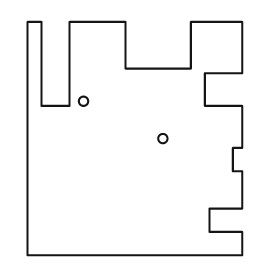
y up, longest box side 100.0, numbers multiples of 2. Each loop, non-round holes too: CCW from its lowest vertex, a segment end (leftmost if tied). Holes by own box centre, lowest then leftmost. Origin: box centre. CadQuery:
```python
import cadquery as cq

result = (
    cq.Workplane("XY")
    .moveTo(-46.0, -50.0)
    .lineTo(46.0, -50.0)
    .lineTo(46.0, -40.0)
    .lineTo(32.0, -40.0)
    .lineTo(32.0, -30.0)
    .lineTo(46.0, -30.0)
    .lineTo(46.0, -14.0)
    .lineTo(42.0, -14.0)
    .lineTo(42.0, -4.0)
    .lineTo(46.0, -4.0)
    .lineTo(46.0, 14.0)
    .lineTo(30.0, 14.0)
    .lineTo(30.0, 28.0)
    .lineTo(46.0, 28.0)
    .lineTo(46.0, 50.0)
    .lineTo(24.0, 50.0)
    .lineTo(24.0, 30.0)
    .lineTo(-4.0, 30.0)
    .lineTo(-4.0, 50.0)
    .lineTo(-28.0, 50.0)
    .lineTo(-28.0, 14.0)
    .lineTo(-40.0, 14.0)
    .lineTo(-40.0, 50.0)
    .lineTo(-46.0, 50.0)
    .close()
    .moveTo(12.0, 0.0)
    .circle(2.0)
    .moveTo(-22.0, 16.0)
    .circle(2.0)
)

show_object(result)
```